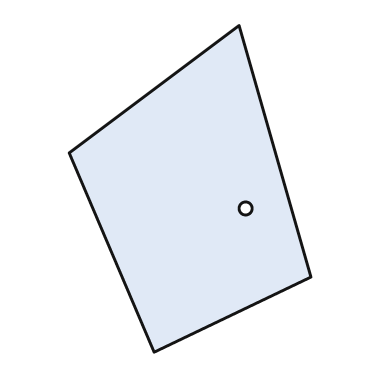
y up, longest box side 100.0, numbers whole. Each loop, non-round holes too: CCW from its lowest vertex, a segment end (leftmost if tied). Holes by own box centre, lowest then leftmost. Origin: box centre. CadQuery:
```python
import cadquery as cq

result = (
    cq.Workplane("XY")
    .moveTo(-11.0, -50.0)
    .lineTo(37.0, -27.0)
    .lineTo(15.0, 50.0)
    .lineTo(-37.0, 11.0)
    .close()
    .moveTo(17.0, -6.0)
    .circle(2.0)
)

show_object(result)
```